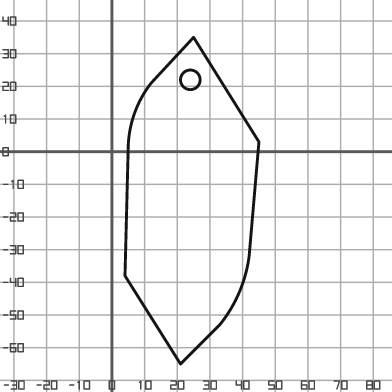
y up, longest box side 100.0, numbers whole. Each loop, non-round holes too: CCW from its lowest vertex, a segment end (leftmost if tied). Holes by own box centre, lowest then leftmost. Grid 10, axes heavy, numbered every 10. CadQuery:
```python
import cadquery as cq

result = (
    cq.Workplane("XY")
    .moveTo(21.0, -65.0)
    .lineTo(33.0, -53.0)
    .threePointArc((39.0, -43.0), (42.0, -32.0))
    .lineTo(45.0, 3.0)
    .lineTo(25.0, 35.0)
    .lineTo(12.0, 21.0)
    .threePointArc((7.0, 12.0), (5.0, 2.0))
    .lineTo(4.0, -38.0)
    .close()
    .moveTo(24.0, 22.0)
    .circle(3.0)
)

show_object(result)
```